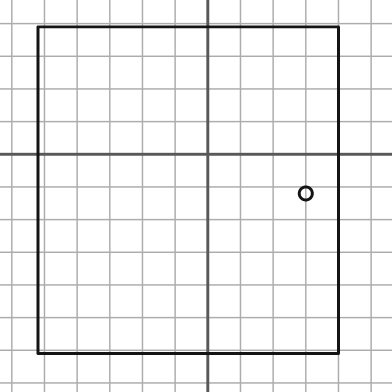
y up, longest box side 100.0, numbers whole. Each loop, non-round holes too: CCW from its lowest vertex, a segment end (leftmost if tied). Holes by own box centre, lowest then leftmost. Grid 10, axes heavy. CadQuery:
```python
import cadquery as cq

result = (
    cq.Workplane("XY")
    .moveTo(-52.0, -61.0)
    .lineTo(40.0, -61.0)
    .lineTo(40.0, 39.0)
    .lineTo(-52.0, 39.0)
    .close()
    .moveTo(30.0, -12.0)
    .circle(2.0)
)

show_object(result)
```